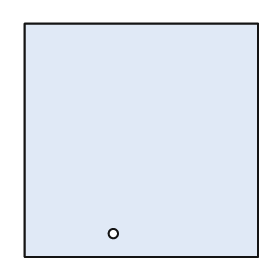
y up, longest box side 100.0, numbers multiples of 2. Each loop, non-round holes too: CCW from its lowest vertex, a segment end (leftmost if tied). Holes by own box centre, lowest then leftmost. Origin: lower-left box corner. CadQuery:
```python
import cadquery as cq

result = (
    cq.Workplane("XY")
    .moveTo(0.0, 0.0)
    .lineTo(100.0, 0.0)
    .lineTo(100.0, 100.0)
    .lineTo(0.0, 100.0)
    .close()
    .moveTo(38.0, 10.0)
    .circle(2.0)
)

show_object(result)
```